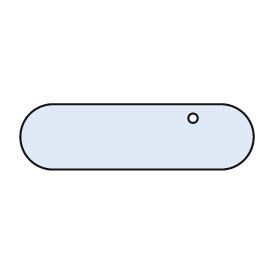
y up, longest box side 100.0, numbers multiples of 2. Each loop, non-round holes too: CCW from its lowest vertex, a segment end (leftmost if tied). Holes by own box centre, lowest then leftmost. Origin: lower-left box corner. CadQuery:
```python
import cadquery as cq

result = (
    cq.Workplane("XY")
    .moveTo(14.0, 0.0)
    .lineTo(86.0, 0.0)
    .threePointArc((100.0, 14.0), (86.0, 28.0))
    .lineTo(14.0, 28.0)
    .threePointArc((0.0, 14.0), (14.0, 0.0))
    .close()
    .moveTo(74.0, 22.0)
    .circle(2.0)
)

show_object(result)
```